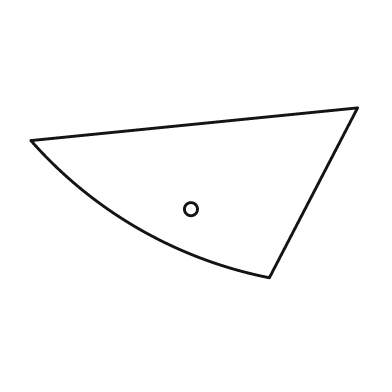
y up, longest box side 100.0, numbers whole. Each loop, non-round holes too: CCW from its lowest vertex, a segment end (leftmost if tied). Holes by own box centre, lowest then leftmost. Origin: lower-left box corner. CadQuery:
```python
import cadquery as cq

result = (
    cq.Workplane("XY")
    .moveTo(73.0, 0.0)
    .lineTo(100.0, 52.0)
    .lineTo(0.0, 42.0)
    .threePointArc((33.0, 15.0), (73.0, 0.0))
    .close()
    .moveTo(49.0, 21.0)
    .circle(2.0)
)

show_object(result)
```